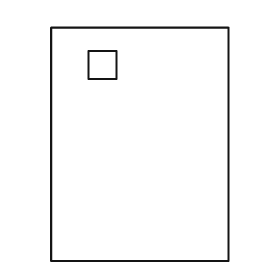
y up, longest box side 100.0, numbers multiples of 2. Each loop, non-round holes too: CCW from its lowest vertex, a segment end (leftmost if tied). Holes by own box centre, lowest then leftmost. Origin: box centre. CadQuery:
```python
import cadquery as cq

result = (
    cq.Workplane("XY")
    .moveTo(-38.0, -50.0)
    .lineTo(38.0, -50.0)
    .lineTo(38.0, 50.0)
    .lineTo(-38.0, 50.0)
    .close()
    .moveTo(-22.0, 28.0)
    .lineTo(-10.0, 28.0)
    .lineTo(-10.0, 40.0)
    .lineTo(-22.0, 40.0)
    .close()
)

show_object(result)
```